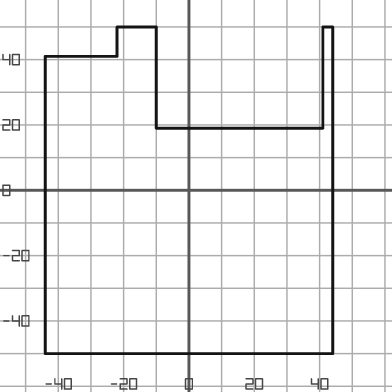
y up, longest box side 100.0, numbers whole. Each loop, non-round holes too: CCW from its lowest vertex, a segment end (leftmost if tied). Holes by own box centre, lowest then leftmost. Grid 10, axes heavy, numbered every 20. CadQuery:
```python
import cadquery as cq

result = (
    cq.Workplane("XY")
    .moveTo(-44.0, -50.0)
    .lineTo(44.0, -50.0)
    .lineTo(44.0, 50.0)
    .lineTo(41.0, 50.0)
    .lineTo(41.0, 19.0)
    .lineTo(-10.0, 19.0)
    .lineTo(-10.0, 50.0)
    .lineTo(-22.0, 50.0)
    .lineTo(-22.0, 41.0)
    .lineTo(-44.0, 41.0)
    .close()
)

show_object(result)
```